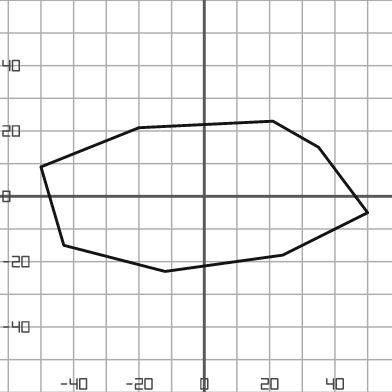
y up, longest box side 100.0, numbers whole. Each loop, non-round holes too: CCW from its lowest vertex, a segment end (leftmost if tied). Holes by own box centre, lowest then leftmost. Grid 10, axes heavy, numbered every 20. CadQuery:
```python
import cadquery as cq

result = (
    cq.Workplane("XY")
    .moveTo(-12.0, -23.0)
    .lineTo(24.0, -18.0)
    .lineTo(50.0, -5.0)
    .lineTo(35.0, 15.0)
    .lineTo(21.0, 23.0)
    .lineTo(-20.0, 21.0)
    .lineTo(-50.0, 9.0)
    .lineTo(-43.0, -15.0)
    .close()
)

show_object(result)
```